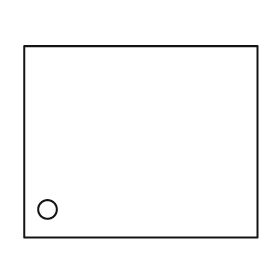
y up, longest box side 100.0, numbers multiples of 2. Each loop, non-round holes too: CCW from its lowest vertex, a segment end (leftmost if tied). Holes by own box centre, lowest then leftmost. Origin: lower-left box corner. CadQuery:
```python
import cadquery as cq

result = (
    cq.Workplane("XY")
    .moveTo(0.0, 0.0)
    .lineTo(100.0, 0.0)
    .lineTo(100.0, 82.0)
    .lineTo(0.0, 82.0)
    .close()
    .moveTo(10.0, 12.0)
    .circle(4.0)
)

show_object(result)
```